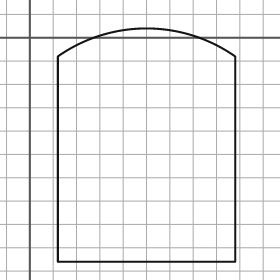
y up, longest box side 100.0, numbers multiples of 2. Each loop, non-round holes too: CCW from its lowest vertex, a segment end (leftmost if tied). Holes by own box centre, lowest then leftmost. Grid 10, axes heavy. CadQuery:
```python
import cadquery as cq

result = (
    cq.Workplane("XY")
    .moveTo(12.0, -96.0)
    .lineTo(88.0, -96.0)
    .lineTo(88.0, -8.0)
    .threePointArc((50.0, 4.0), (12.0, -8.0))
    .close()
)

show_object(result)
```